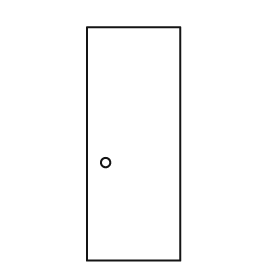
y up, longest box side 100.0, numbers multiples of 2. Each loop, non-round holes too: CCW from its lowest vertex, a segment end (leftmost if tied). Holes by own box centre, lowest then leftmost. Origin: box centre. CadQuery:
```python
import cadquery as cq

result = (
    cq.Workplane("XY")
    .moveTo(-20.0, -50.0)
    .lineTo(20.0, -50.0)
    .lineTo(20.0, 50.0)
    .lineTo(-20.0, 50.0)
    .close()
    .moveTo(-12.0, -8.0)
    .circle(2.0)
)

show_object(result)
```